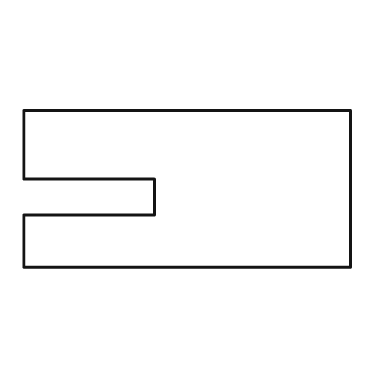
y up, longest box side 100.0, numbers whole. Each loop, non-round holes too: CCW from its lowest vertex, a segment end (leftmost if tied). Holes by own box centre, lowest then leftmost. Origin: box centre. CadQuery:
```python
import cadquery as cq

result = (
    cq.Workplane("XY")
    .moveTo(-50.0, -24.0)
    .lineTo(50.0, -24.0)
    .lineTo(50.0, 24.0)
    .lineTo(-50.0, 24.0)
    .lineTo(-50.0, 3.0)
    .lineTo(-10.0, 3.0)
    .lineTo(-10.0, -8.0)
    .lineTo(-50.0, -8.0)
    .close()
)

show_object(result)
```